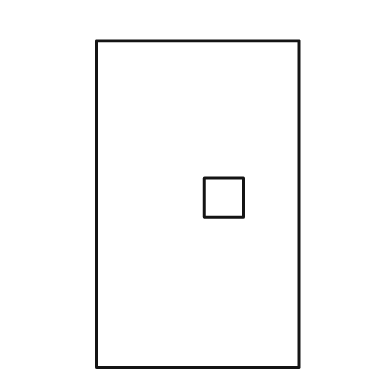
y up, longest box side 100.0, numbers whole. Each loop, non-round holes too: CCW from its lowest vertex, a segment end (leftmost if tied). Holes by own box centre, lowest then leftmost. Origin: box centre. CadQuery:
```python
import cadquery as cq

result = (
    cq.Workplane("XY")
    .moveTo(-31.0, -50.0)
    .lineTo(31.0, -50.0)
    .lineTo(31.0, 50.0)
    .lineTo(-31.0, 50.0)
    .close()
    .moveTo(2.0, -4.0)
    .lineTo(14.0, -4.0)
    .lineTo(14.0, 8.0)
    .lineTo(2.0, 8.0)
    .close()
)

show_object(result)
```